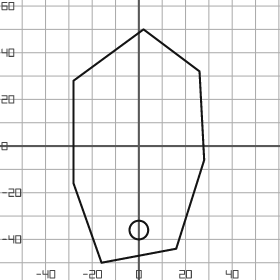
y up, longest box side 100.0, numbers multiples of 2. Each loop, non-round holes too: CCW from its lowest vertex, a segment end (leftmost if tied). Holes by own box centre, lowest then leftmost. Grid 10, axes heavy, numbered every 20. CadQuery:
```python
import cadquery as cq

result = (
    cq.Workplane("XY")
    .moveTo(-16.0, -50.0)
    .lineTo(16.0, -44.0)
    .lineTo(28.0, -6.0)
    .lineTo(26.0, 32.0)
    .lineTo(2.0, 50.0)
    .lineTo(-28.0, 28.0)
    .lineTo(-28.0, -16.0)
    .close()
    .moveTo(0.0, -36.0)
    .circle(4.0)
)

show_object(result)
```